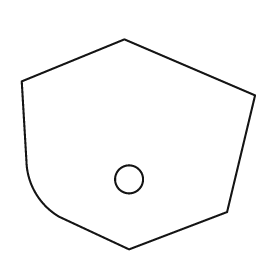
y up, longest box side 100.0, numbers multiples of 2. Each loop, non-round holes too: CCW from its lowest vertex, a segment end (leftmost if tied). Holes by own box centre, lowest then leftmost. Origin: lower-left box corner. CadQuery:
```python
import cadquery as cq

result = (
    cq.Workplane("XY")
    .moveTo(46.0, 0.0)
    .lineTo(88.0, 16.0)
    .lineTo(100.0, 66.0)
    .lineTo(44.0, 90.0)
    .lineTo(0.0, 72.0)
    .lineTo(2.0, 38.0)
    .threePointArc((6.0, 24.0), (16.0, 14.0))
    .close()
    .moveTo(46.0, 30.0)
    .circle(6.0)
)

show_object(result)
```